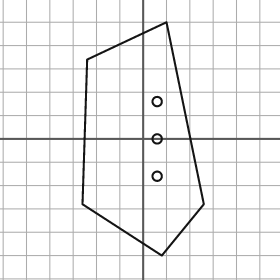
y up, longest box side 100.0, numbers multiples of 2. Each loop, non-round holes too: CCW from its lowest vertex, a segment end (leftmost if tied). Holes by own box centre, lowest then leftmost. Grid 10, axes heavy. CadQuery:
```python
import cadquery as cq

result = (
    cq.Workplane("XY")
    .moveTo(8.0, -50.0)
    .lineTo(26.0, -28.0)
    .lineTo(10.0, 50.0)
    .lineTo(-24.0, 34.0)
    .lineTo(-26.0, -28.0)
    .close()
    .moveTo(6.0, -16.0)
    .circle(2.0)
    .moveTo(6.0, 0.0)
    .circle(2.0)
    .moveTo(6.0, 16.0)
    .circle(2.0)
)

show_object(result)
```